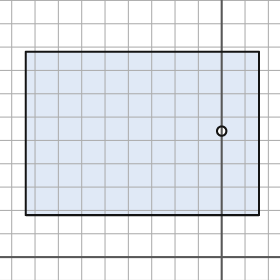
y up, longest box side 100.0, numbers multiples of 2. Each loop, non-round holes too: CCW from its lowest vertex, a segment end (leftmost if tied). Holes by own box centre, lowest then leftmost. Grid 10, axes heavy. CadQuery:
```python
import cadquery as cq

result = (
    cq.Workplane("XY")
    .moveTo(-84.0, 18.0)
    .lineTo(16.0, 18.0)
    .lineTo(16.0, 88.0)
    .lineTo(-84.0, 88.0)
    .close()
    .moveTo(0.0, 54.0)
    .circle(2.0)
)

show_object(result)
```